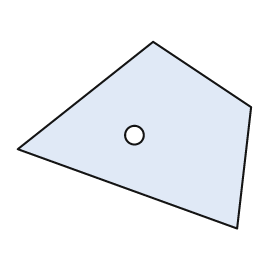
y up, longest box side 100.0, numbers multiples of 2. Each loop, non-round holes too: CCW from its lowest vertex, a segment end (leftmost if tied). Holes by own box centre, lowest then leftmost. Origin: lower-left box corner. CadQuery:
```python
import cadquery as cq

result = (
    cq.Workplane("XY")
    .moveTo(94.0, 0.0)
    .lineTo(100.0, 52.0)
    .lineTo(58.0, 80.0)
    .lineTo(0.0, 34.0)
    .close()
    .moveTo(50.0, 40.0)
    .circle(4.0)
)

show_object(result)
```